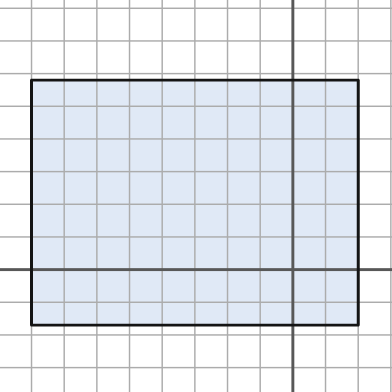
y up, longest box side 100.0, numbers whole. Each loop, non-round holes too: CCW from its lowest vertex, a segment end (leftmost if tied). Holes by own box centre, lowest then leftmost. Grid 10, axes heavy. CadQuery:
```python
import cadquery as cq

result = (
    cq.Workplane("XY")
    .moveTo(-80.0, -17.0)
    .lineTo(20.0, -17.0)
    .lineTo(20.0, 58.0)
    .lineTo(-80.0, 58.0)
    .close()
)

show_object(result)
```